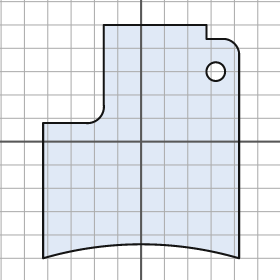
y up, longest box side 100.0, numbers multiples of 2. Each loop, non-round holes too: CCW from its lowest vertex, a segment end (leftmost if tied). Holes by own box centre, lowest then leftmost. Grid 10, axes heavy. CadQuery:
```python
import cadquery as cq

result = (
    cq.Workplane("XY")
    .moveTo(-42.0, -50.0)
    .threePointArc((0.0, -44.0), (42.0, -50.0))
    .lineTo(42.0, 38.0)
    .threePointArc((40.0, 42.0), (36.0, 44.0))
    .lineTo(28.0, 44.0)
    .lineTo(28.0, 50.0)
    .lineTo(-16.0, 50.0)
    .lineTo(-16.0, 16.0)
    .threePointArc((-18.0, 10.0), (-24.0, 8.0))
    .lineTo(-42.0, 8.0)
    .close()
    .moveTo(32.0, 30.0)
    .circle(4.0)
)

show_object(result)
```